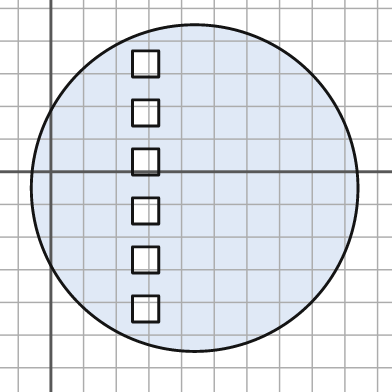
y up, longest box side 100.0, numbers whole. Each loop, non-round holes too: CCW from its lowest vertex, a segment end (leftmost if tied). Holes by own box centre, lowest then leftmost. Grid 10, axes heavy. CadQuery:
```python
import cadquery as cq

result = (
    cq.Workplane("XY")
    .moveTo(44.0, -5.0)
    .circle(50.0)
    .moveTo(25.0, -46.0)
    .lineTo(33.0, -46.0)
    .lineTo(33.0, -38.0)
    .lineTo(25.0, -38.0)
    .close()
    .moveTo(25.0, -31.0)
    .lineTo(33.0, -31.0)
    .lineTo(33.0, -23.0)
    .lineTo(25.0, -23.0)
    .close()
    .moveTo(25.0, -16.0)
    .lineTo(33.0, -16.0)
    .lineTo(33.0, -8.0)
    .lineTo(25.0, -8.0)
    .close()
    .moveTo(25.0, -1.0)
    .lineTo(33.0, -1.0)
    .lineTo(33.0, 7.0)
    .lineTo(25.0, 7.0)
    .close()
    .moveTo(25.0, 14.0)
    .lineTo(33.0, 14.0)
    .lineTo(33.0, 22.0)
    .lineTo(25.0, 22.0)
    .close()
    .moveTo(25.0, 29.0)
    .lineTo(33.0, 29.0)
    .lineTo(33.0, 37.0)
    .lineTo(25.0, 37.0)
    .close()
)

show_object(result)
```